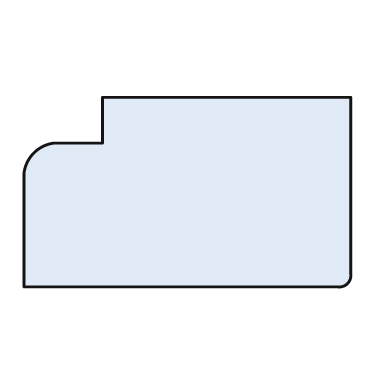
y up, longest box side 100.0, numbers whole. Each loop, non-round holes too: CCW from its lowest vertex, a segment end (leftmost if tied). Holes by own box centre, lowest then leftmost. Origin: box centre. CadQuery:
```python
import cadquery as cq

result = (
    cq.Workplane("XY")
    .moveTo(-50.0, -29.0)
    .lineTo(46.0, -29.0)
    .threePointArc((49.0, -28.0), (50.0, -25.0))
    .lineTo(50.0, 29.0)
    .lineTo(-26.0, 29.0)
    .lineTo(-26.0, 15.0)
    .lineTo(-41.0, 15.0)
    .threePointArc((-47.0, 12.0), (-50.0, 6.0))
    .close()
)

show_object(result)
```